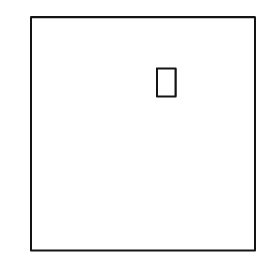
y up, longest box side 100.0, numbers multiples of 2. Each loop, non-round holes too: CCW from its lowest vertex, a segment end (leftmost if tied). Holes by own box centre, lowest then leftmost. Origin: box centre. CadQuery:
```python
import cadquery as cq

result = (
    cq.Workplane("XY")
    .moveTo(-48.0, -50.0)
    .lineTo(48.0, -50.0)
    .lineTo(48.0, 50.0)
    .lineTo(-48.0, 50.0)
    .close()
    .moveTo(6.0, 16.0)
    .lineTo(14.0, 16.0)
    .lineTo(14.0, 28.0)
    .lineTo(6.0, 28.0)
    .close()
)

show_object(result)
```